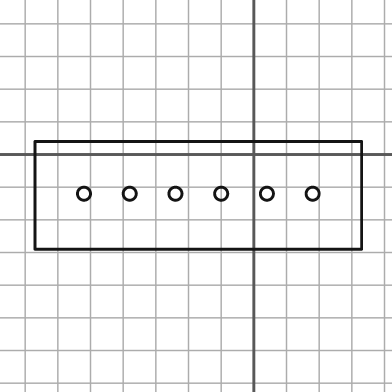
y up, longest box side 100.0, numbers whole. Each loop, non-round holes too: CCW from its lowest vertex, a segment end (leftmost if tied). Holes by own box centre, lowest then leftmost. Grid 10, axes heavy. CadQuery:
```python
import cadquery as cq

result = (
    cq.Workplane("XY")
    .moveTo(-67.0, -29.0)
    .lineTo(33.0, -29.0)
    .lineTo(33.0, 4.0)
    .lineTo(-67.0, 4.0)
    .close()
    .moveTo(-52.0, -12.0)
    .circle(2.0)
    .moveTo(-38.0, -12.0)
    .circle(2.0)
    .moveTo(-24.0, -12.0)
    .circle(2.0)
    .moveTo(-10.0, -12.0)
    .circle(2.0)
    .moveTo(4.0, -12.0)
    .circle(2.0)
    .moveTo(18.0, -12.0)
    .circle(2.0)
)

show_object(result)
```